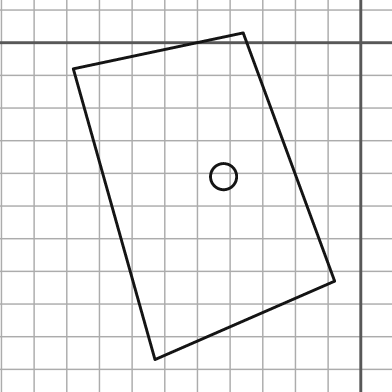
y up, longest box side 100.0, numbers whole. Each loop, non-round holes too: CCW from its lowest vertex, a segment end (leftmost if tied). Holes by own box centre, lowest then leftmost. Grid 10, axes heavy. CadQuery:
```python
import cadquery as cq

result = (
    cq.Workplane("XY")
    .moveTo(-63.0, -97.0)
    .lineTo(-8.0, -73.0)
    .lineTo(-36.0, 3.0)
    .lineTo(-88.0, -8.0)
    .close()
    .moveTo(-42.0, -41.0)
    .circle(4.0)
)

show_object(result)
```